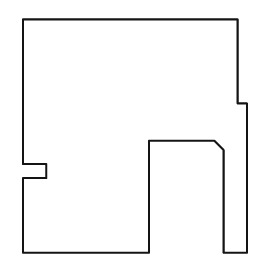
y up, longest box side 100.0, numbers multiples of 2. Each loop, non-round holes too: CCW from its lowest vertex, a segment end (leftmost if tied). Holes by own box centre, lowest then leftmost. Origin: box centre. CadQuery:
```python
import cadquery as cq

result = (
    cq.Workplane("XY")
    .moveTo(-48.0, -50.0)
    .lineTo(6.0, -50.0)
    .lineTo(6.0, -2.0)
    .lineTo(34.0, -2.0)
    .lineTo(38.0, -6.0)
    .lineTo(38.0, -50.0)
    .lineTo(48.0, -50.0)
    .lineTo(48.0, 14.0)
    .lineTo(44.0, 14.0)
    .lineTo(44.0, 50.0)
    .lineTo(-48.0, 50.0)
    .lineTo(-48.0, -12.0)
    .lineTo(-38.0, -12.0)
    .lineTo(-38.0, -18.0)
    .lineTo(-48.0, -18.0)
    .close()
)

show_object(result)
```